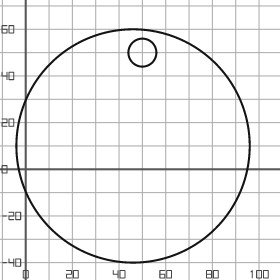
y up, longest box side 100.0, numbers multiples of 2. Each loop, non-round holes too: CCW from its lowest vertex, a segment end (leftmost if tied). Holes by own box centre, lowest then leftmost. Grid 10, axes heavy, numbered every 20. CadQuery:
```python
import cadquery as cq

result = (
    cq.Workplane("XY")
    .moveTo(46.0, 10.0)
    .circle(50.0)
    .moveTo(50.0, 50.0)
    .circle(6.0)
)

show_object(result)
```